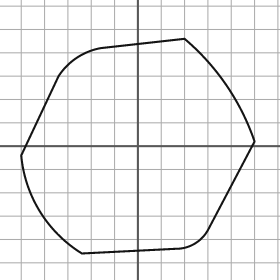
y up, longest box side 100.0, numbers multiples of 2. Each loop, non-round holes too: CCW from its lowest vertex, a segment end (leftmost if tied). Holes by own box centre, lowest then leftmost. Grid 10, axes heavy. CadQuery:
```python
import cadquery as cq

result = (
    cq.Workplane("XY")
    .moveTo(-24.0, -46.0)
    .lineTo(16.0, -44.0)
    .threePointArc((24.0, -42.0), (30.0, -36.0))
    .lineTo(50.0, 2.0)
    .threePointArc((38.0, 26.0), (20.0, 46.0))
    .lineTo(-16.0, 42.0)
    .threePointArc((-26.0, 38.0), (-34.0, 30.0))
    .lineTo(-50.0, -4.0)
    .threePointArc((-42.0, -28.0), (-24.0, -46.0))
    .close()
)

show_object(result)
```